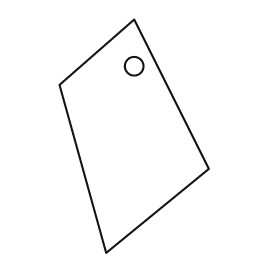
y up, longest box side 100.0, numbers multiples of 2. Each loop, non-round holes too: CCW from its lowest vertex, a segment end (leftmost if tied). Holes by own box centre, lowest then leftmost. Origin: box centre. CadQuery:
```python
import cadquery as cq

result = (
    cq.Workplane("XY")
    .moveTo(-12.0, -50.0)
    .lineTo(32.0, -14.0)
    .lineTo(0.0, 50.0)
    .lineTo(-32.0, 22.0)
    .close()
    .moveTo(0.0, 30.0)
    .circle(4.0)
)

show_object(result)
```